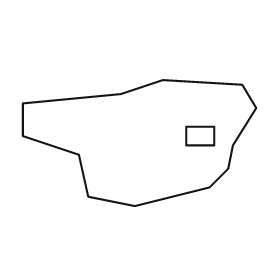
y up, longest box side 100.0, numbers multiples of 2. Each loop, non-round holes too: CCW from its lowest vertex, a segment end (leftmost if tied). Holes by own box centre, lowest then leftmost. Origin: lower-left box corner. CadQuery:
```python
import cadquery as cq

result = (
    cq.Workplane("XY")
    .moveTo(48.0, 0.0)
    .lineTo(80.0, 8.0)
    .lineTo(88.0, 16.0)
    .lineTo(90.0, 26.0)
    .lineTo(100.0, 42.0)
    .lineTo(94.0, 52.0)
    .lineTo(60.0, 54.0)
    .lineTo(42.0, 48.0)
    .lineTo(0.0, 44.0)
    .lineTo(0.0, 30.0)
    .lineTo(24.0, 22.0)
    .lineTo(28.0, 4.0)
    .close()
    .moveTo(70.0, 26.0)
    .lineTo(82.0, 26.0)
    .lineTo(82.0, 34.0)
    .lineTo(70.0, 34.0)
    .close()
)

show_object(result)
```